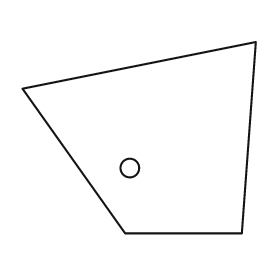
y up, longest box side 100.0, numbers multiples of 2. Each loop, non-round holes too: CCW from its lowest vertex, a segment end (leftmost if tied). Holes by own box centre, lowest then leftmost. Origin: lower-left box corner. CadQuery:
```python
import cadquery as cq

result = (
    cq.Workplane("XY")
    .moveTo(44.0, 0.0)
    .lineTo(94.0, 0.0)
    .lineTo(100.0, 82.0)
    .lineTo(0.0, 62.0)
    .close()
    .moveTo(46.0, 28.0)
    .circle(4.0)
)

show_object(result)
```